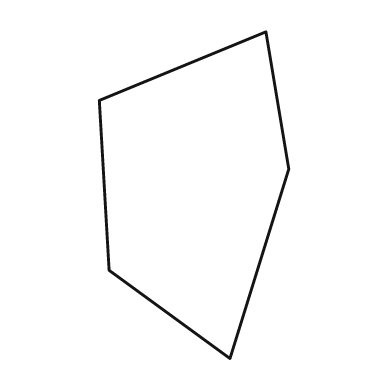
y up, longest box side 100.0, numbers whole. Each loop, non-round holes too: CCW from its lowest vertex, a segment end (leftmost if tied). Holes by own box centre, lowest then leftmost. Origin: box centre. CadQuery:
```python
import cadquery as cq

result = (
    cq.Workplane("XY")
    .moveTo(11.0, -50.0)
    .lineTo(29.0, 8.0)
    .lineTo(22.0, 50.0)
    .lineTo(-29.0, 29.0)
    .lineTo(-26.0, -23.0)
    .close()
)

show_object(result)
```